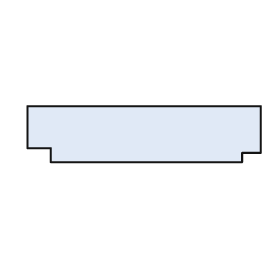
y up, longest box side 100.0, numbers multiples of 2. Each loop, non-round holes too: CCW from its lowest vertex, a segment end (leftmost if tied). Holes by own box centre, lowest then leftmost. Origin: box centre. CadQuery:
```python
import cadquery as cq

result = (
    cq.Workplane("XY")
    .moveTo(-40.0, -12.0)
    .lineTo(42.0, -12.0)
    .lineTo(42.0, -8.0)
    .lineTo(50.0, -8.0)
    .lineTo(50.0, 12.0)
    .lineTo(-50.0, 12.0)
    .lineTo(-50.0, -6.0)
    .lineTo(-40.0, -6.0)
    .close()
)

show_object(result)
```